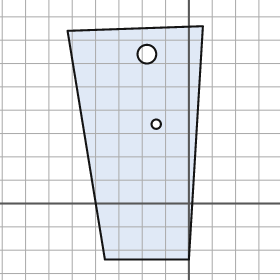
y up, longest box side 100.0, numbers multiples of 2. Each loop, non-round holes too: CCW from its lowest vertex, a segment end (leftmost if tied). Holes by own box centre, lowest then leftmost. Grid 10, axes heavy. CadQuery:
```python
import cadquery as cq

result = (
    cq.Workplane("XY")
    .moveTo(-36.0, -24.0)
    .lineTo(0.0, -24.0)
    .lineTo(6.0, 76.0)
    .lineTo(-52.0, 74.0)
    .close()
    .moveTo(-14.0, 34.0)
    .circle(2.0)
    .moveTo(-18.0, 64.0)
    .circle(4.0)
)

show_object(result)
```